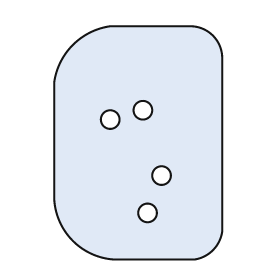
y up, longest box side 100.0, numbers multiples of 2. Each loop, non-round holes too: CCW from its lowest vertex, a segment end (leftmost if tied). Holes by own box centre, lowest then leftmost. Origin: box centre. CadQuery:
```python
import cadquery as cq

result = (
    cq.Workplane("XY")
    .moveTo(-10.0, -50.0)
    .lineTo(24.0, -50.0)
    .threePointArc((32.0, -46.0), (36.0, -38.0))
    .lineTo(36.0, 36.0)
    .threePointArc((32.0, 46.0), (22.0, 50.0))
    .lineTo(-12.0, 50.0)
    .threePointArc((-28.0, 42.0), (-36.0, 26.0))
    .lineTo(-36.0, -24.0)
    .threePointArc((-28.0, -42.0), (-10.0, -50.0))
    .close()
    .moveTo(4.0, -30.0)
    .circle(4.0)
    .moveTo(10.0, -14.0)
    .circle(4.0)
    .moveTo(-12.0, 10.0)
    .circle(4.0)
    .moveTo(2.0, 14.0)
    .circle(4.0)
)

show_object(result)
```